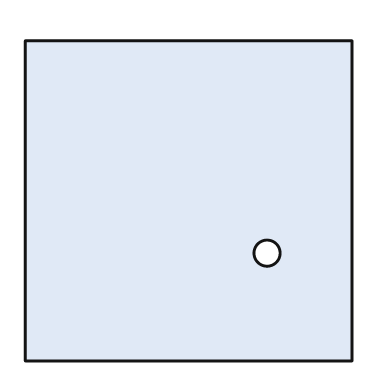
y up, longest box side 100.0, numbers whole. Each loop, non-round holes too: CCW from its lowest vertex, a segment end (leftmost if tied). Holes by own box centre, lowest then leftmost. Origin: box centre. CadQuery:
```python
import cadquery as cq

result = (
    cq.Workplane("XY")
    .moveTo(-50.0, -49.0)
    .lineTo(50.0, -49.0)
    .lineTo(50.0, 49.0)
    .lineTo(-50.0, 49.0)
    .close()
    .moveTo(24.0, -16.0)
    .circle(4.0)
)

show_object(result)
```